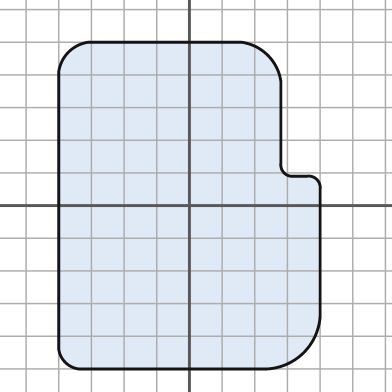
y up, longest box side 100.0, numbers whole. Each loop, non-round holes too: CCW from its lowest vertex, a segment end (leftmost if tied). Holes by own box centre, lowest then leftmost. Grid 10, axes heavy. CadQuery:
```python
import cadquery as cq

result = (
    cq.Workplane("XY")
    .moveTo(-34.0, -50.0)
    .lineTo(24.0, -50.0)
    .threePointArc((35.0, -45.0), (40.0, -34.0))
    .lineTo(40.0, 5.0)
    .threePointArc((39.0, 8.0), (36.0, 9.0))
    .lineTo(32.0, 9.0)
    .threePointArc((29.0, 10.0), (28.0, 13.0))
    .lineTo(28.0, 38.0)
    .threePointArc((24.0, 46.0), (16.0, 50.0))
    .lineTo(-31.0, 50.0)
    .threePointArc((-37.0, 47.0), (-40.0, 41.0))
    .lineTo(-40.0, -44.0)
    .threePointArc((-38.0, -48.0), (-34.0, -50.0))
    .close()
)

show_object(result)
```